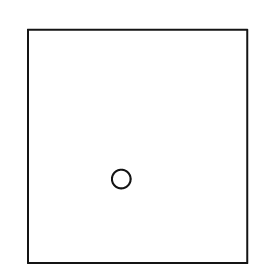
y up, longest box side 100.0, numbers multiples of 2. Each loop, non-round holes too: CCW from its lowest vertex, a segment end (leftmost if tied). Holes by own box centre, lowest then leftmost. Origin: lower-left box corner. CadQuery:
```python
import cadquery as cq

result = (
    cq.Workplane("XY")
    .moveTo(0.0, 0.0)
    .lineTo(94.0, 0.0)
    .lineTo(94.0, 100.0)
    .lineTo(0.0, 100.0)
    .close()
    .moveTo(40.0, 36.0)
    .circle(4.0)
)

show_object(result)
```